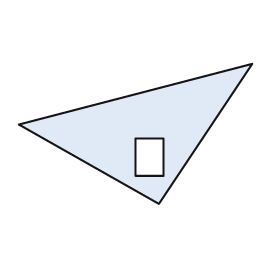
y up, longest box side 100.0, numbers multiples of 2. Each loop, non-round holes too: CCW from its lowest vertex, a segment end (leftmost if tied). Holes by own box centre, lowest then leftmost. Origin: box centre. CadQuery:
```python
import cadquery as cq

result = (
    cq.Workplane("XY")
    .moveTo(10.0, -30.0)
    .lineTo(50.0, 30.0)
    .lineTo(-50.0, 4.0)
    .close()
    .moveTo(0.0, -18.0)
    .lineTo(12.0, -18.0)
    .lineTo(12.0, -2.0)
    .lineTo(0.0, -2.0)
    .close()
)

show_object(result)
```